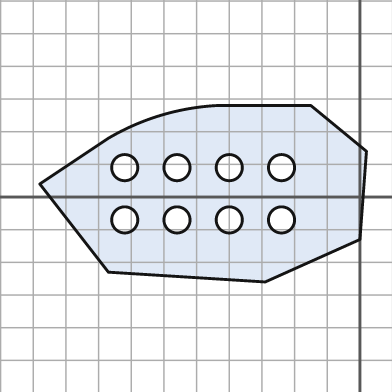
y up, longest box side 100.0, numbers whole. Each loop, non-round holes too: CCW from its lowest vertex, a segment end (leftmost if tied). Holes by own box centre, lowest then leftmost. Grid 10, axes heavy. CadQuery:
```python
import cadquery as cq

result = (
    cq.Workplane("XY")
    .moveTo(-29.0, -26.0)
    .lineTo(0.0, -13.0)
    .lineTo(2.0, 14.0)
    .lineTo(-15.0, 28.0)
    .lineTo(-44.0, 28.0)
    .threePointArc((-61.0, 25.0), (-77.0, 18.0))
    .lineTo(-98.0, 4.0)
    .lineTo(-77.0, -23.0)
    .close()
    .moveTo(-72.0, -7.0)
    .circle(4.0)
    .moveTo(-56.0, -7.0)
    .circle(4.0)
    .moveTo(-40.0, -7.0)
    .circle(4.0)
    .moveTo(-24.0, -7.0)
    .circle(4.0)
    .moveTo(-72.0, 9.0)
    .circle(4.0)
    .moveTo(-56.0, 9.0)
    .circle(4.0)
    .moveTo(-40.0, 9.0)
    .circle(4.0)
    .moveTo(-24.0, 9.0)
    .circle(4.0)
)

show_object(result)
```